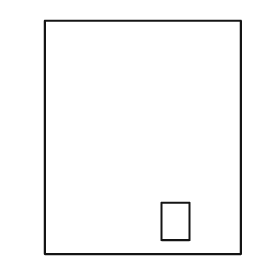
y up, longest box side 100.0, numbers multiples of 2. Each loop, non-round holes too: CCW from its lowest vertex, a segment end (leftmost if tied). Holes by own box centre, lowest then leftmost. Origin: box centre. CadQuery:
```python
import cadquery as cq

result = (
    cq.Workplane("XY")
    .moveTo(-42.0, -50.0)
    .lineTo(42.0, -50.0)
    .lineTo(42.0, 50.0)
    .lineTo(-42.0, 50.0)
    .close()
    .moveTo(8.0, -44.0)
    .lineTo(20.0, -44.0)
    .lineTo(20.0, -28.0)
    .lineTo(8.0, -28.0)
    .close()
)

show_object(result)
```